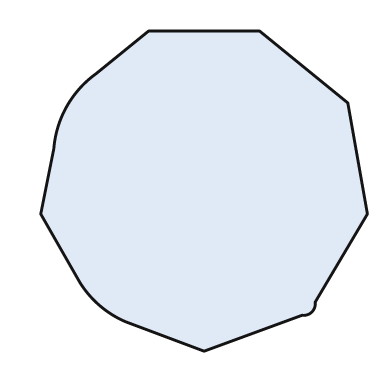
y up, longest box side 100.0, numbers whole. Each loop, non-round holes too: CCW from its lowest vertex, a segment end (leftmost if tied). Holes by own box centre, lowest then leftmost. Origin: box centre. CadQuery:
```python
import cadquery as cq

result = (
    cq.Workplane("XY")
    .moveTo(0.0, -49.0)
    .lineTo(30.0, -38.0)
    .threePointArc((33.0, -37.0), (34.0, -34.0))
    .lineTo(50.0, -7.0)
    .lineTo(44.0, 27.0)
    .lineTo(17.0, 49.0)
    .lineTo(-17.0, 49.0)
    .lineTo(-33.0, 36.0)
    .threePointArc((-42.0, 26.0), (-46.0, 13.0))
    .lineTo(-50.0, -7.0)
    .lineTo(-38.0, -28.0)
    .threePointArc((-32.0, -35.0), (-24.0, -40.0))
    .close()
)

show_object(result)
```